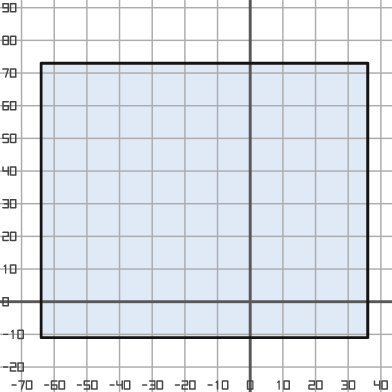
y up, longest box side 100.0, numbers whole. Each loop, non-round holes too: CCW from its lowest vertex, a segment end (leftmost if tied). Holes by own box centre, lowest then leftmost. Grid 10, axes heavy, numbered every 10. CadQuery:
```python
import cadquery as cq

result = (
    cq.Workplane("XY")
    .moveTo(-64.0, -11.0)
    .lineTo(36.0, -11.0)
    .lineTo(36.0, 73.0)
    .lineTo(-64.0, 73.0)
    .close()
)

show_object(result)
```